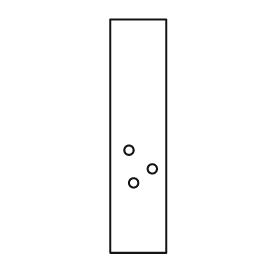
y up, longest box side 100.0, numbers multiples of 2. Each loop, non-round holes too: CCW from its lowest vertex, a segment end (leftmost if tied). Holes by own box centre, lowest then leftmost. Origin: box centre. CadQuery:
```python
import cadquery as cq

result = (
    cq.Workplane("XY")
    .moveTo(-12.0, -50.0)
    .lineTo(12.0, -50.0)
    .lineTo(12.0, 50.0)
    .lineTo(-12.0, 50.0)
    .close()
    .moveTo(-2.0, -20.0)
    .circle(2.0)
    .moveTo(6.0, -14.0)
    .circle(2.0)
    .moveTo(-4.0, -6.0)
    .circle(2.0)
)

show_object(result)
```